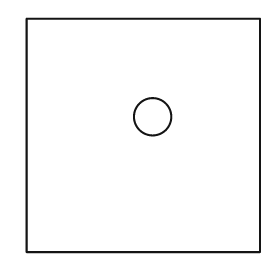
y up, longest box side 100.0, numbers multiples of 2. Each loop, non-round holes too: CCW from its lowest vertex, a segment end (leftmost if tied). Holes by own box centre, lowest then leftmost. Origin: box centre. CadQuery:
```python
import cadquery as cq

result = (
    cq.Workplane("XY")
    .moveTo(-50.0, -50.0)
    .lineTo(50.0, -50.0)
    .lineTo(50.0, 50.0)
    .lineTo(-50.0, 50.0)
    .close()
    .moveTo(4.0, 8.0)
    .circle(8.0)
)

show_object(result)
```